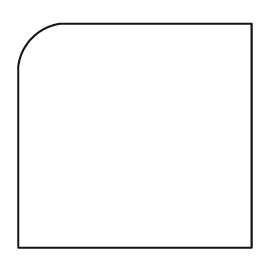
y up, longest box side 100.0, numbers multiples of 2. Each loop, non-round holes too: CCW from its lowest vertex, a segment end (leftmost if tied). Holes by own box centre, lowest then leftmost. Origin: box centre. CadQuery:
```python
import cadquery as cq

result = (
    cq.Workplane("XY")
    .moveTo(-50.0, -48.0)
    .lineTo(50.0, -48.0)
    .lineTo(50.0, 48.0)
    .lineTo(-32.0, 48.0)
    .threePointArc((-44.0, 42.0), (-50.0, 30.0))
    .close()
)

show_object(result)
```